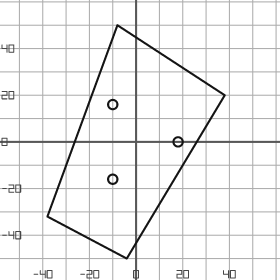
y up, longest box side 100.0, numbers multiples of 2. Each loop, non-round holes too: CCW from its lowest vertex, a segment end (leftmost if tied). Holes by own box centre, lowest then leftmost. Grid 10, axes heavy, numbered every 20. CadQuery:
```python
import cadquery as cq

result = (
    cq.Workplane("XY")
    .moveTo(-4.0, -50.0)
    .lineTo(38.0, 20.0)
    .lineTo(-8.0, 50.0)
    .lineTo(-38.0, -32.0)
    .close()
    .moveTo(-10.0, -16.0)
    .circle(2.0)
    .moveTo(18.0, 0.0)
    .circle(2.0)
    .moveTo(-10.0, 16.0)
    .circle(2.0)
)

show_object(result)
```